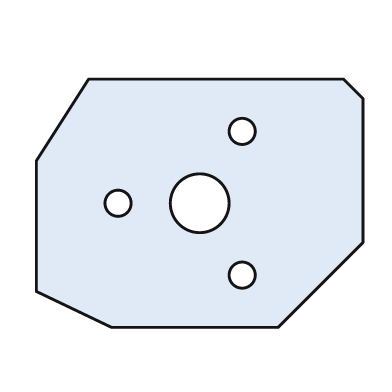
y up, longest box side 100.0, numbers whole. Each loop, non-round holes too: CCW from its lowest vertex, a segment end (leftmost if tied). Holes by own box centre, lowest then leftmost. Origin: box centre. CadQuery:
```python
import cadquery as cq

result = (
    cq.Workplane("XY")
    .moveTo(-27.0, -38.0)
    .lineTo(24.0, -38.0)
    .lineTo(50.0, -12.0)
    .lineTo(50.0, 32.0)
    .lineTo(44.0, 38.0)
    .lineTo(-34.0, 38.0)
    .lineTo(-50.0, 13.0)
    .lineTo(-50.0, -27.0)
    .close()
    .moveTo(13.0, -22.0)
    .circle(4.0)
    .moveTo(-25.0, 0.0)
    .circle(4.0)
    .moveTo(0.0, 0.0)
    .circle(9.0)
    .moveTo(13.0, 22.0)
    .circle(4.0)
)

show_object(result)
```